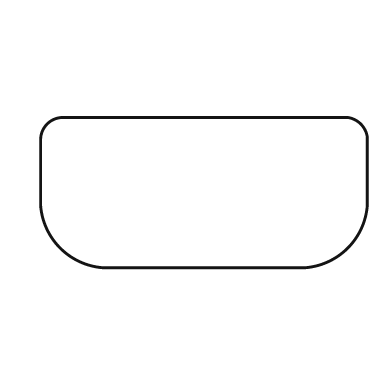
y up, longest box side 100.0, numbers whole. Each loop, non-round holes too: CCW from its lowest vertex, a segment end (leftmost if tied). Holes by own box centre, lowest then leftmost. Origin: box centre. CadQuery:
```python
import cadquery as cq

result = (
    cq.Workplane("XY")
    .moveTo(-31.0, -23.0)
    .lineTo(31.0, -23.0)
    .threePointArc((44.0, -17.0), (50.0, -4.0))
    .lineTo(50.0, 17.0)
    .threePointArc((48.0, 21.0), (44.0, 23.0))
    .lineTo(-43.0, 23.0)
    .threePointArc((-48.0, 21.0), (-50.0, 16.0))
    .lineTo(-50.0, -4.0)
    .threePointArc((-44.0, -17.0), (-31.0, -23.0))
    .close()
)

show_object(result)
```